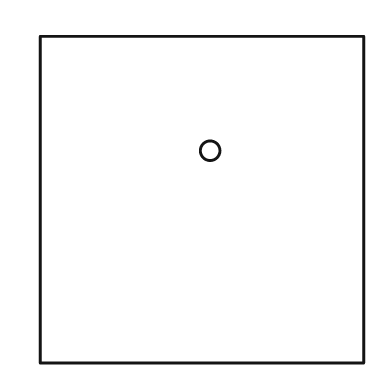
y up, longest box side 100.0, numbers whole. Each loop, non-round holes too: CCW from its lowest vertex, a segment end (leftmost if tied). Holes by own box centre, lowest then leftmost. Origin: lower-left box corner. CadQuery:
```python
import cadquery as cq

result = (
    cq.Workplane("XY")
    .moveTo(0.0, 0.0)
    .lineTo(99.0, 0.0)
    .lineTo(99.0, 100.0)
    .lineTo(0.0, 100.0)
    .close()
    .moveTo(52.0, 65.0)
    .circle(3.0)
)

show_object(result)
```